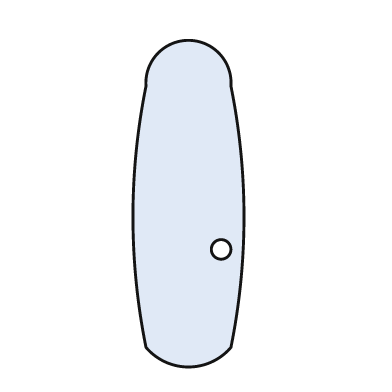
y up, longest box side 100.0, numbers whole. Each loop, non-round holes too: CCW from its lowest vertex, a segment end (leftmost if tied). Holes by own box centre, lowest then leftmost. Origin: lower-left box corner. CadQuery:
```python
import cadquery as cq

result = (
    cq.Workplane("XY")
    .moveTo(4.0, 6.0)
    .threePointArc((17.0, 0.0), (30.0, 6.0))
    .threePointArc((34.0, 46.0), (30.0, 86.0))
    .threePointArc((17.0, 100.0), (4.0, 86.0))
    .threePointArc((0.0, 46.0), (4.0, 6.0))
    .close()
    .moveTo(27.0, 36.0)
    .circle(3.0)
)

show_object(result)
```